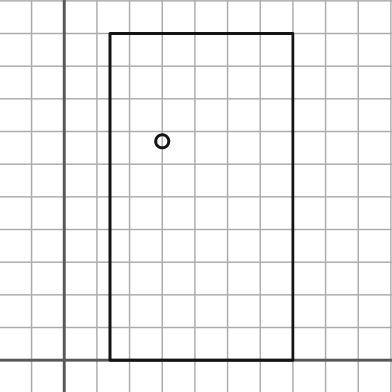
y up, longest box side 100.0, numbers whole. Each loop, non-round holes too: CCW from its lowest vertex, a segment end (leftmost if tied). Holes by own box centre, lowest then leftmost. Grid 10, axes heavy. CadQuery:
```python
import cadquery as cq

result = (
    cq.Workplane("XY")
    .moveTo(14.0, 0.0)
    .lineTo(70.0, 0.0)
    .lineTo(70.0, 100.0)
    .lineTo(14.0, 100.0)
    .close()
    .moveTo(30.0, 67.0)
    .circle(2.0)
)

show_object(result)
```